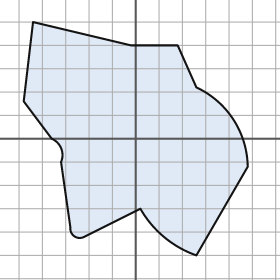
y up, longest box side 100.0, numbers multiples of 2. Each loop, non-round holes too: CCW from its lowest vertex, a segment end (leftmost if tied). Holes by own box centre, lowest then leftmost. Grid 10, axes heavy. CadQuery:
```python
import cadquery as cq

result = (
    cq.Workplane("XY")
    .moveTo(26.0, -50.0)
    .lineTo(48.0, -12.0)
    .threePointArc((42.0, 8.0), (26.0, 22.0))
    .lineTo(18.0, 40.0)
    .lineTo(-2.0, 40.0)
    .lineTo(-44.0, 50.0)
    .lineTo(-48.0, 16.0)
    .lineTo(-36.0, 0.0)
    .threePointArc((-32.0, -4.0), (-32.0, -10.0))
    .lineTo(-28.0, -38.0)
    .threePointArc((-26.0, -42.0), (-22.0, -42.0))
    .lineTo(2.0, -30.0)
    .threePointArc((12.0, -42.0), (26.0, -50.0))
    .close()
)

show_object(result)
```